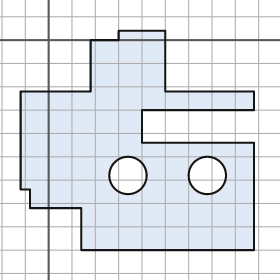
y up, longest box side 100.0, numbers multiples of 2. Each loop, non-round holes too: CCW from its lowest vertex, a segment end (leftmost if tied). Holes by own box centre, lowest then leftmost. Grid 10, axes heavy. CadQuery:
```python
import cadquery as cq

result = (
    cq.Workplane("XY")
    .moveTo(14.0, -90.0)
    .lineTo(88.0, -90.0)
    .lineTo(88.0, -44.0)
    .lineTo(40.0, -44.0)
    .lineTo(40.0, -30.0)
    .lineTo(88.0, -30.0)
    .lineTo(88.0, -22.0)
    .lineTo(50.0, -22.0)
    .lineTo(50.0, 4.0)
    .lineTo(30.0, 4.0)
    .lineTo(30.0, 0.0)
    .lineTo(18.0, 0.0)
    .lineTo(18.0, -22.0)
    .lineTo(-12.0, -22.0)
    .lineTo(-12.0, -64.0)
    .lineTo(-8.0, -64.0)
    .lineTo(-8.0, -72.0)
    .lineTo(14.0, -72.0)
    .close()
    .moveTo(34.0, -58.0)
    .circle(8.0)
    .moveTo(68.0, -58.0)
    .circle(8.0)
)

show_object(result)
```